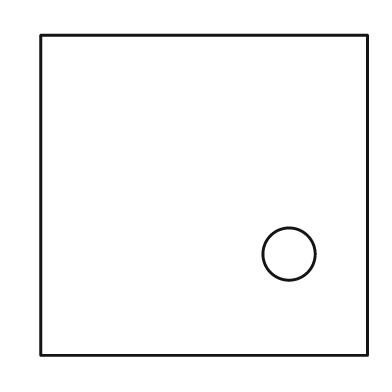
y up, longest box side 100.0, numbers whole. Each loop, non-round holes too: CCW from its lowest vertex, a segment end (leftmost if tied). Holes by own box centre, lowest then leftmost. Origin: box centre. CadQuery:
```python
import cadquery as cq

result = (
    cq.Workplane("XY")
    .moveTo(-50.0, -49.0)
    .lineTo(50.0, -49.0)
    .lineTo(50.0, 49.0)
    .lineTo(-50.0, 49.0)
    .close()
    .moveTo(26.0, -18.0)
    .circle(8.0)
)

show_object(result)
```